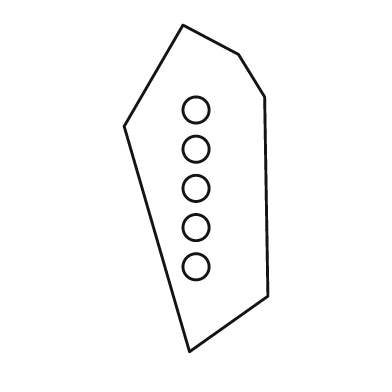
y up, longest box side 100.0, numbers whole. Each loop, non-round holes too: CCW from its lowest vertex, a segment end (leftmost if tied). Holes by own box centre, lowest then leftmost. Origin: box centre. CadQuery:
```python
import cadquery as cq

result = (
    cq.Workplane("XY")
    .moveTo(-2.0, -50.0)
    .lineTo(22.0, -33.0)
    .lineTo(21.0, 28.0)
    .lineTo(13.0, 41.0)
    .lineTo(-4.0, 50.0)
    .lineTo(-22.0, 19.0)
    .close()
    .moveTo(0.0, -24.0)
    .circle(4.0)
    .moveTo(0.0, -12.0)
    .circle(4.0)
    .moveTo(0.0, 0.0)
    .circle(4.0)
    .moveTo(0.0, 12.0)
    .circle(4.0)
    .moveTo(0.0, 24.0)
    .circle(4.0)
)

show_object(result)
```